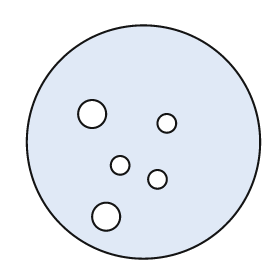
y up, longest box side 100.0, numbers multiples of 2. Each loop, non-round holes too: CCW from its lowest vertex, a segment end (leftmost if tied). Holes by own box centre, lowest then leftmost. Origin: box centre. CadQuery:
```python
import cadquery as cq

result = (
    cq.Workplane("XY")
    .moveTo(0.0, 0.0)
    .circle(50.0)
    .moveTo(-16.0, -32.0)
    .circle(6.0)
    .moveTo(6.0, -16.0)
    .circle(4.0)
    .moveTo(-10.0, -10.0)
    .circle(4.0)
    .moveTo(10.0, 8.0)
    .circle(4.0)
    .moveTo(-22.0, 12.0)
    .circle(6.0)
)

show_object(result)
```